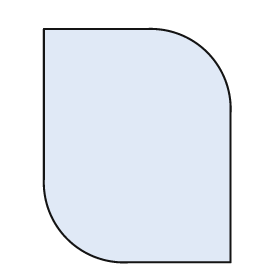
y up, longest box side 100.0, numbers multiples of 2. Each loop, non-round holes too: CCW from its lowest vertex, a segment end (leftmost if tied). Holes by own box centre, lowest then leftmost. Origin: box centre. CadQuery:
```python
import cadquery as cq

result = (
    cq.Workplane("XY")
    .moveTo(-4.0, -50.0)
    .lineTo(40.0, -50.0)
    .lineTo(40.0, 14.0)
    .threePointArc((30.0, 40.0), (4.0, 50.0))
    .lineTo(-40.0, 50.0)
    .lineTo(-40.0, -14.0)
    .threePointArc((-30.0, -40.0), (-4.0, -50.0))
    .close()
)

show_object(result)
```